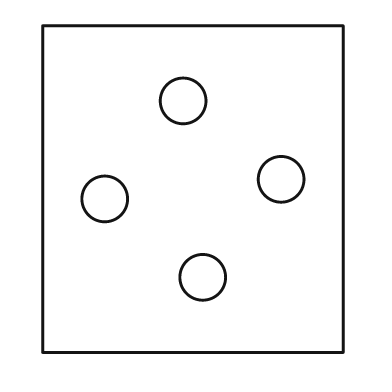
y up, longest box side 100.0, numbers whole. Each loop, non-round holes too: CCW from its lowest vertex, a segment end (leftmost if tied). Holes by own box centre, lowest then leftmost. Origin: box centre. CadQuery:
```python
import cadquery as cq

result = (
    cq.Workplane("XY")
    .moveTo(-46.0, -50.0)
    .lineTo(46.0, -50.0)
    .lineTo(46.0, 50.0)
    .lineTo(-46.0, 50.0)
    .close()
    .moveTo(3.0, -27.0)
    .circle(7.0)
    .moveTo(-27.0, -3.0)
    .circle(7.0)
    .moveTo(27.0, 3.0)
    .circle(7.0)
    .moveTo(-3.0, 27.0)
    .circle(7.0)
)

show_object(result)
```